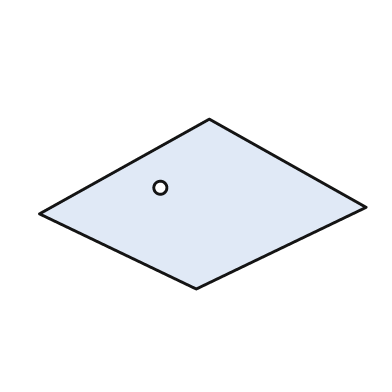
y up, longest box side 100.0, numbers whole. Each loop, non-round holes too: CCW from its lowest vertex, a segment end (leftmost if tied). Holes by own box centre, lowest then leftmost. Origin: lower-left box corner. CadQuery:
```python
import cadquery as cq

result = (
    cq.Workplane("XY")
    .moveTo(48.0, 0.0)
    .lineTo(100.0, 25.0)
    .lineTo(52.0, 52.0)
    .lineTo(0.0, 23.0)
    .close()
    .moveTo(37.0, 31.0)
    .circle(2.0)
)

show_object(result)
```